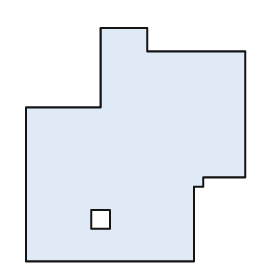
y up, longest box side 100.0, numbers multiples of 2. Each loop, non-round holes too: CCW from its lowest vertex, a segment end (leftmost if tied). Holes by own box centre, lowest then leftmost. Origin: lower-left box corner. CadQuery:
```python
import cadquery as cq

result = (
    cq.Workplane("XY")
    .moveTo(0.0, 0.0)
    .lineTo(72.0, 0.0)
    .lineTo(72.0, 32.0)
    .lineTo(76.0, 32.0)
    .lineTo(76.0, 36.0)
    .lineTo(94.0, 36.0)
    .lineTo(94.0, 90.0)
    .lineTo(52.0, 90.0)
    .lineTo(52.0, 100.0)
    .lineTo(32.0, 100.0)
    .lineTo(32.0, 66.0)
    .lineTo(0.0, 66.0)
    .close()
    .moveTo(28.0, 14.0)
    .lineTo(36.0, 14.0)
    .lineTo(36.0, 22.0)
    .lineTo(28.0, 22.0)
    .close()
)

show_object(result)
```